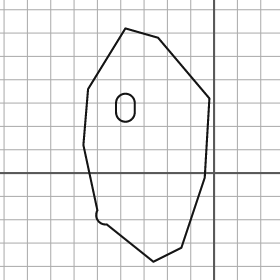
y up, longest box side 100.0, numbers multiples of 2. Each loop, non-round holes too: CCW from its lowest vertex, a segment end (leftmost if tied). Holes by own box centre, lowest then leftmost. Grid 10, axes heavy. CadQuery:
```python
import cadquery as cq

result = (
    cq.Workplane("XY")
    .moveTo(-26.0, -38.0)
    .lineTo(-14.0, -32.0)
    .lineTo(-4.0, -2.0)
    .lineTo(-2.0, 32.0)
    .lineTo(-24.0, 58.0)
    .lineTo(-38.0, 62.0)
    .lineTo(-54.0, 36.0)
    .lineTo(-56.0, 12.0)
    .lineTo(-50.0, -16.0)
    .threePointArc((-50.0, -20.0), (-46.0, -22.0))
    .close()
    .moveTo(-42.0, 26.0)
    .threePointArc((-38.0, 22.0), (-34.0, 26.0))
    .lineTo(-34.0, 30.0)
    .threePointArc((-38.0, 34.0), (-42.0, 30.0))
    .close()
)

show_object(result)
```